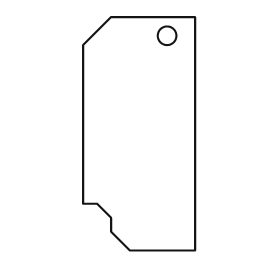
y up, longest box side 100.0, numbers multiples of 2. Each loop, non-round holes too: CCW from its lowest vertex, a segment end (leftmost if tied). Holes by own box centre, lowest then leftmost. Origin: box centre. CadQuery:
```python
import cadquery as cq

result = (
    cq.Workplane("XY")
    .moveTo(-4.0, -50.0)
    .lineTo(24.0, -50.0)
    .lineTo(24.0, 50.0)
    .lineTo(-12.0, 50.0)
    .lineTo(-24.0, 38.0)
    .lineTo(-24.0, -30.0)
    .lineTo(-18.0, -30.0)
    .lineTo(-12.0, -36.0)
    .lineTo(-12.0, -42.0)
    .close()
    .moveTo(12.0, 42.0)
    .circle(4.0)
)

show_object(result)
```